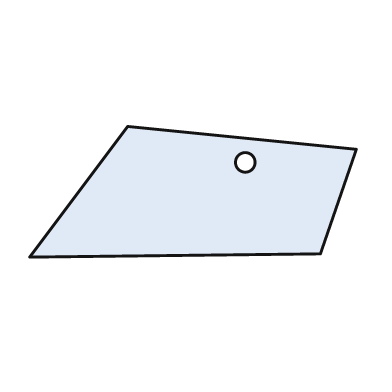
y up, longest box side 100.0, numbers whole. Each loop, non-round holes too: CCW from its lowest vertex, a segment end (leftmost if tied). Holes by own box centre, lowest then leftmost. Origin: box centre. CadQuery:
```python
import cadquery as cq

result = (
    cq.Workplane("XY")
    .moveTo(-50.0, -20.0)
    .lineTo(39.0, -19.0)
    .lineTo(50.0, 13.0)
    .lineTo(-20.0, 20.0)
    .close()
    .moveTo(16.0, 9.0)
    .circle(3.0)
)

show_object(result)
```